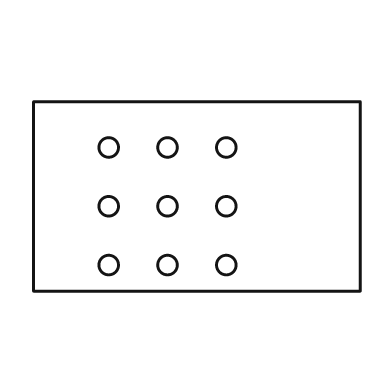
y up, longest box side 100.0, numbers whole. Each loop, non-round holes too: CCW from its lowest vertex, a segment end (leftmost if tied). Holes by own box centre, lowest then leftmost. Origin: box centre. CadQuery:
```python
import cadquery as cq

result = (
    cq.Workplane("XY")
    .moveTo(-50.0, -29.0)
    .lineTo(50.0, -29.0)
    .lineTo(50.0, 29.0)
    .lineTo(-50.0, 29.0)
    .close()
    .moveTo(-27.0, -21.0)
    .circle(3.0)
    .moveTo(-9.0, -21.0)
    .circle(3.0)
    .moveTo(9.0, -21.0)
    .circle(3.0)
    .moveTo(-27.0, -3.0)
    .circle(3.0)
    .moveTo(-9.0, -3.0)
    .circle(3.0)
    .moveTo(9.0, -3.0)
    .circle(3.0)
    .moveTo(-27.0, 15.0)
    .circle(3.0)
    .moveTo(-9.0, 15.0)
    .circle(3.0)
    .moveTo(9.0, 15.0)
    .circle(3.0)
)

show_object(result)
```